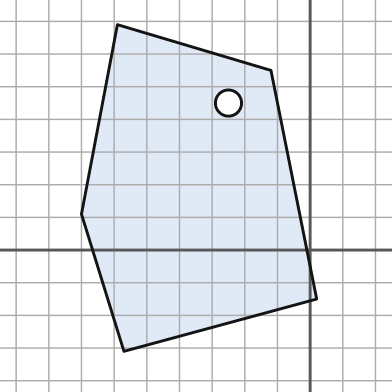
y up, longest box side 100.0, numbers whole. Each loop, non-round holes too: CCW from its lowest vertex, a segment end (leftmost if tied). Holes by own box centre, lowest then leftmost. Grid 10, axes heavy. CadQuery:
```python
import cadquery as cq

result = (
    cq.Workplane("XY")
    .moveTo(-57.0, -31.0)
    .lineTo(2.0, -15.0)
    .lineTo(-12.0, 55.0)
    .lineTo(-59.0, 69.0)
    .lineTo(-70.0, 11.0)
    .close()
    .moveTo(-25.0, 45.0)
    .circle(4.0)
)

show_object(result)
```